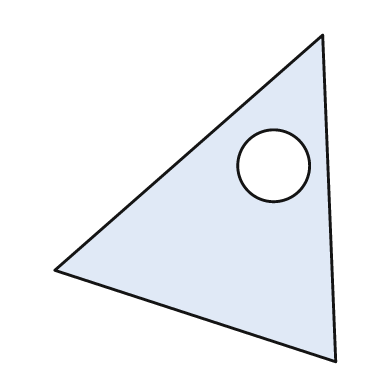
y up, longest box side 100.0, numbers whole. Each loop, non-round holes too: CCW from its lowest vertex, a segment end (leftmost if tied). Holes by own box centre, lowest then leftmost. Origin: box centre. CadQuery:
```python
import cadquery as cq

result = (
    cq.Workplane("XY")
    .moveTo(43.0, -50.0)
    .lineTo(39.0, 50.0)
    .lineTo(-43.0, -22.0)
    .close()
    .moveTo(24.0, 10.0)
    .circle(11.0)
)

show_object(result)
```